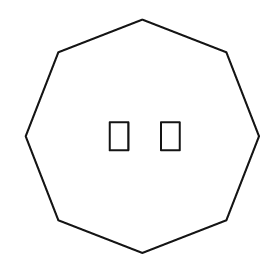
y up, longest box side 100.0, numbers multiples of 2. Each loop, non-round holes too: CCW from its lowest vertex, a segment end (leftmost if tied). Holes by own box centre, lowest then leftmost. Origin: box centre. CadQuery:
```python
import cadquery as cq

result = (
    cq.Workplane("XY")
    .moveTo(0.0, -50.0)
    .lineTo(36.0, -36.0)
    .lineTo(50.0, 0.0)
    .lineTo(36.0, 36.0)
    .lineTo(0.0, 50.0)
    .lineTo(-36.0, 36.0)
    .lineTo(-50.0, 0.0)
    .lineTo(-36.0, -36.0)
    .close()
    .moveTo(-14.0, -6.0)
    .lineTo(-6.0, -6.0)
    .lineTo(-6.0, 6.0)
    .lineTo(-14.0, 6.0)
    .close()
    .moveTo(8.0, -6.0)
    .lineTo(16.0, -6.0)
    .lineTo(16.0, 6.0)
    .lineTo(8.0, 6.0)
    .close()
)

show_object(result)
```